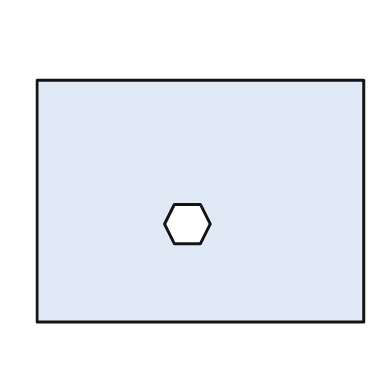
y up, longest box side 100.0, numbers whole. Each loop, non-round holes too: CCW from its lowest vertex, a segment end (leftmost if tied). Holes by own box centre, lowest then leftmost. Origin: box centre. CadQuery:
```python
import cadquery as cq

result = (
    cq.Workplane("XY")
    .moveTo(-50.0, -37.0)
    .lineTo(50.0, -37.0)
    .lineTo(50.0, 37.0)
    .lineTo(-50.0, 37.0)
    .close()
    .moveTo(-8.0, -13.0)
    .lineTo(0.0, -13.0)
    .lineTo(3.0, -7.0)
    .lineTo(0.0, -1.0)
    .lineTo(-8.0, -1.0)
    .lineTo(-11.0, -7.0)
    .close()
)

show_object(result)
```